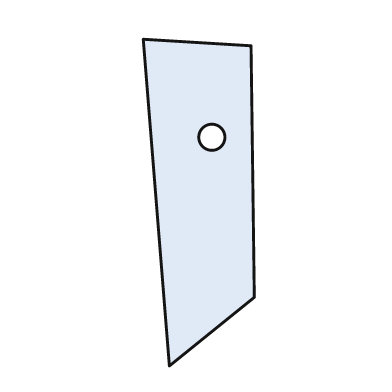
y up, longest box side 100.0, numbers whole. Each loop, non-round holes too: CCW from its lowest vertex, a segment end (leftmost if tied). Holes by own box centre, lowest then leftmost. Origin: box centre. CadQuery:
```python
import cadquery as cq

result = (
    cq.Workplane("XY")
    .moveTo(-9.0, -50.0)
    .lineTo(17.0, -29.0)
    .lineTo(16.0, 48.0)
    .lineTo(-17.0, 50.0)
    .close()
    .moveTo(4.0, 20.0)
    .circle(4.0)
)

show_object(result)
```